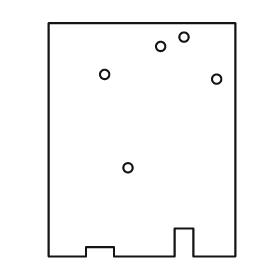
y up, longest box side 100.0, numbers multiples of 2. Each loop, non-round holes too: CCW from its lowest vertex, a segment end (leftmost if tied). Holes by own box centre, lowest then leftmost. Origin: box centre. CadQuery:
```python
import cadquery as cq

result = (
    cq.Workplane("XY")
    .moveTo(-40.0, -50.0)
    .lineTo(-24.0, -50.0)
    .lineTo(-24.0, -46.0)
    .lineTo(-12.0, -46.0)
    .lineTo(-12.0, -50.0)
    .lineTo(14.0, -50.0)
    .lineTo(14.0, -38.0)
    .lineTo(22.0, -38.0)
    .lineTo(22.0, -50.0)
    .lineTo(40.0, -50.0)
    .lineTo(40.0, 50.0)
    .lineTo(-40.0, 50.0)
    .close()
    .moveTo(-6.0, -12.0)
    .circle(2.0)
    .moveTo(32.0, 26.0)
    .circle(2.0)
    .moveTo(-16.0, 28.0)
    .circle(2.0)
    .moveTo(8.0, 40.0)
    .circle(2.0)
    .moveTo(18.0, 44.0)
    .circle(2.0)
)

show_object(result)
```